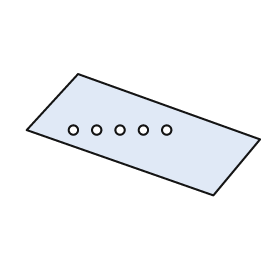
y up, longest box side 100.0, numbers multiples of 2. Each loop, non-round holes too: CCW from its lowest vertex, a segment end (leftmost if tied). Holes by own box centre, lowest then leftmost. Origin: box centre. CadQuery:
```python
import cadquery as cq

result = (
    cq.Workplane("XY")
    .moveTo(30.0, -26.0)
    .lineTo(50.0, -2.0)
    .lineTo(-28.0, 26.0)
    .lineTo(-50.0, 2.0)
    .close()
    .moveTo(-30.0, 2.0)
    .circle(2.0)
    .moveTo(-20.0, 2.0)
    .circle(2.0)
    .moveTo(-10.0, 2.0)
    .circle(2.0)
    .moveTo(0.0, 2.0)
    .circle(2.0)
    .moveTo(10.0, 2.0)
    .circle(2.0)
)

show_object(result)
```